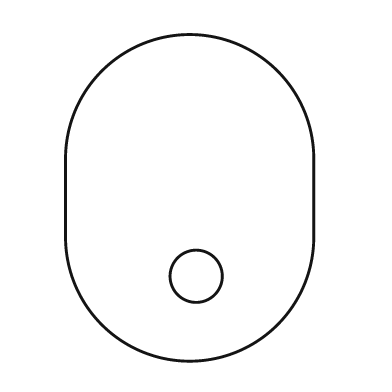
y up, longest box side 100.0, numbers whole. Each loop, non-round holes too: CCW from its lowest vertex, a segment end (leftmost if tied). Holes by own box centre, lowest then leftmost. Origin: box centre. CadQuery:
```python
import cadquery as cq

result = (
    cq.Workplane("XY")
    .moveTo(-38.0, -12.0)
    .threePointArc((0.0, -50.0), (38.0, -12.0))
    .lineTo(38.0, 12.0)
    .threePointArc((0.0, 50.0), (-38.0, 12.0))
    .close()
    .moveTo(2.0, -24.0)
    .circle(8.0)
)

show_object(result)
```